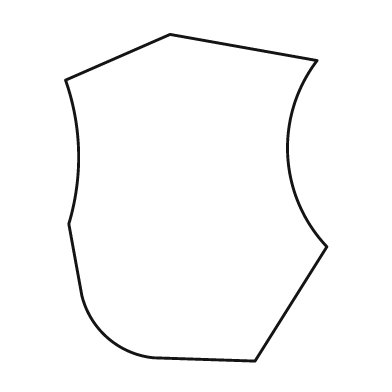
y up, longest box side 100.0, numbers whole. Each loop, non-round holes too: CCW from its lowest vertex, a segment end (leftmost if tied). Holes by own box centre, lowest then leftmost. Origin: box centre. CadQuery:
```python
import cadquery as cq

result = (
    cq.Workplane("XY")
    .moveTo(18.0, -50.0)
    .lineTo(40.0, -15.0)
    .threePointArc((28.0, 13.0), (37.0, 42.0))
    .lineTo(-8.0, 50.0)
    .lineTo(-40.0, 36.0)
    .threePointArc((-36.0, 14.0), (-39.0, -8.0))
    .lineTo(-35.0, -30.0)
    .threePointArc((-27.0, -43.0), (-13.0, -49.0))
    .close()
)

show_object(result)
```